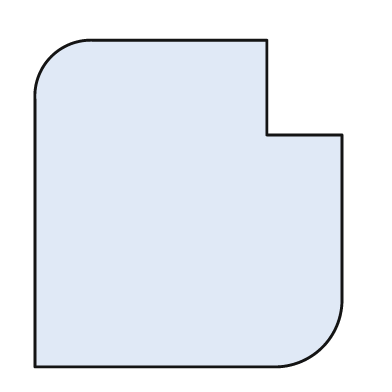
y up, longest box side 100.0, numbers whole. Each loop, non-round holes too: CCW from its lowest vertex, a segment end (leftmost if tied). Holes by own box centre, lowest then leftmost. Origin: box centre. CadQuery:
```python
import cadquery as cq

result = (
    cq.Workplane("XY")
    .moveTo(-47.0, -50.0)
    .lineTo(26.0, -50.0)
    .threePointArc((41.0, -44.0), (47.0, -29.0))
    .lineTo(47.0, 21.0)
    .lineTo(24.0, 21.0)
    .lineTo(24.0, 50.0)
    .lineTo(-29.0, 50.0)
    .threePointArc((-42.0, 45.0), (-47.0, 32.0))
    .close()
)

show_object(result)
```